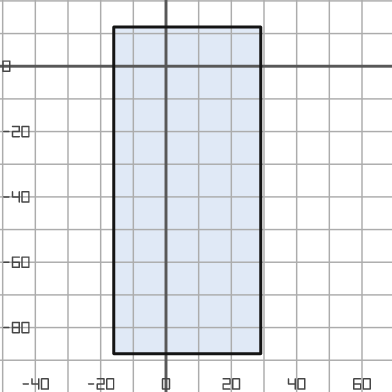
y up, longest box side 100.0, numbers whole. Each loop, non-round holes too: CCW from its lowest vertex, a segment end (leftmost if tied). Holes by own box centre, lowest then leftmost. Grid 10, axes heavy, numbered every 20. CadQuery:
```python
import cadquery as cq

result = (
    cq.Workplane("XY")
    .moveTo(-16.0, -88.0)
    .lineTo(29.0, -88.0)
    .lineTo(29.0, 12.0)
    .lineTo(-16.0, 12.0)
    .close()
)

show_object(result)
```